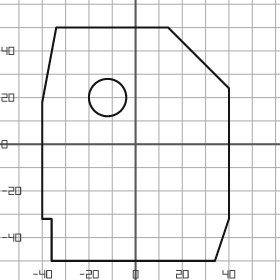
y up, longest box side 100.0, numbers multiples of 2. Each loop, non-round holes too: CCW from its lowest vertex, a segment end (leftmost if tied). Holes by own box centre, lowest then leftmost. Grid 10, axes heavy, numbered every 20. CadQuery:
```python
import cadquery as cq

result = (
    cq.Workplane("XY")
    .moveTo(-36.0, -50.0)
    .lineTo(34.0, -50.0)
    .lineTo(40.0, -32.0)
    .lineTo(40.0, 24.0)
    .lineTo(14.0, 50.0)
    .lineTo(-34.0, 50.0)
    .lineTo(-40.0, 18.0)
    .lineTo(-40.0, -32.0)
    .lineTo(-36.0, -32.0)
    .close()
    .moveTo(-12.0, 20.0)
    .circle(8.0)
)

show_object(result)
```